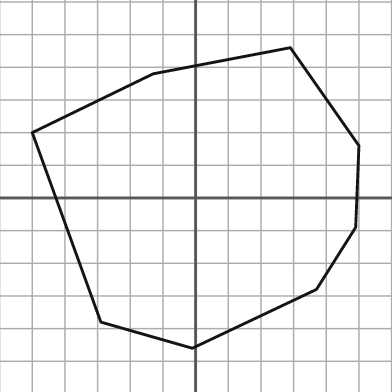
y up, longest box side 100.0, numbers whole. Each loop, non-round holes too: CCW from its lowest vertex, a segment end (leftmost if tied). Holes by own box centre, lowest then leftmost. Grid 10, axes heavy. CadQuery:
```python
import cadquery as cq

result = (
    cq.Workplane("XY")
    .moveTo(-1.0, -46.0)
    .lineTo(37.0, -28.0)
    .lineTo(49.0, -9.0)
    .lineTo(50.0, 16.0)
    .lineTo(29.0, 46.0)
    .lineTo(-13.0, 38.0)
    .lineTo(-50.0, 20.0)
    .lineTo(-29.0, -38.0)
    .close()
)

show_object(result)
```